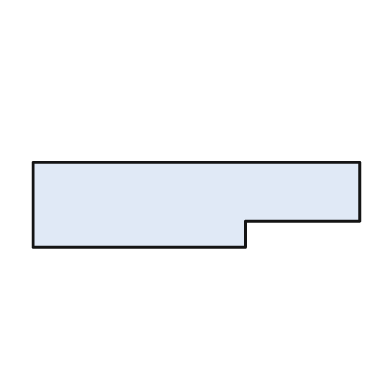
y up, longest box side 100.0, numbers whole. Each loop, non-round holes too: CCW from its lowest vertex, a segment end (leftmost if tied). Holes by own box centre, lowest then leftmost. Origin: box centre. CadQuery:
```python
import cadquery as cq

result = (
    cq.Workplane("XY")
    .moveTo(-50.0, -13.0)
    .lineTo(15.0, -13.0)
    .lineTo(15.0, -5.0)
    .lineTo(50.0, -5.0)
    .lineTo(50.0, 13.0)
    .lineTo(-50.0, 13.0)
    .close()
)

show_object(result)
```